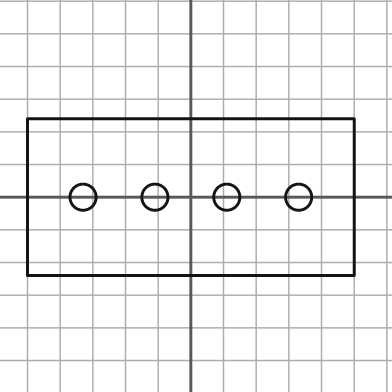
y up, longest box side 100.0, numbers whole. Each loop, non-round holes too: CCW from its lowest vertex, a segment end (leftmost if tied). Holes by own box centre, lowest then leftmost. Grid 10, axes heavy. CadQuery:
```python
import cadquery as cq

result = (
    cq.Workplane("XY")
    .moveTo(-50.0, -24.0)
    .lineTo(50.0, -24.0)
    .lineTo(50.0, 24.0)
    .lineTo(-50.0, 24.0)
    .close()
    .moveTo(-33.0, 0.0)
    .circle(4.0)
    .moveTo(-11.0, 0.0)
    .circle(4.0)
    .moveTo(11.0, 0.0)
    .circle(4.0)
    .moveTo(33.0, 0.0)
    .circle(4.0)
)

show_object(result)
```